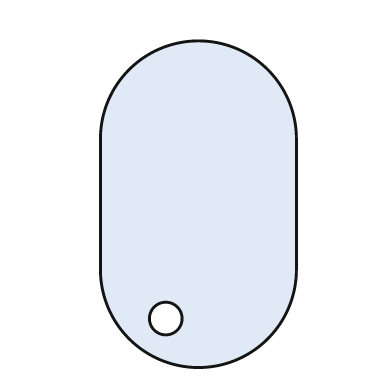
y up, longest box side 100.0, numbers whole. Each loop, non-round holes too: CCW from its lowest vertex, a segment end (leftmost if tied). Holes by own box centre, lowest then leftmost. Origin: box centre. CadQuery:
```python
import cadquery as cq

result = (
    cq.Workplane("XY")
    .moveTo(-30.0, -20.0)
    .threePointArc((0.0, -50.0), (30.0, -20.0))
    .lineTo(30.0, 20.0)
    .threePointArc((0.0, 50.0), (-30.0, 20.0))
    .close()
    .moveTo(-10.0, -35.0)
    .circle(5.0)
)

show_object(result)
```